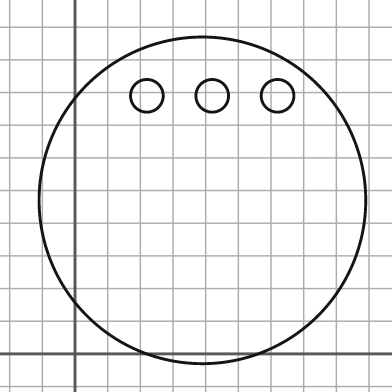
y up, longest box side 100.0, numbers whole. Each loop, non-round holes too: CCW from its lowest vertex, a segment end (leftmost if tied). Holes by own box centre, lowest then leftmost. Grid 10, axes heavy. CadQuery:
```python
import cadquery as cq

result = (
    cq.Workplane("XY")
    .moveTo(39.0, 47.0)
    .circle(50.0)
    .moveTo(22.0, 79.0)
    .circle(5.0)
    .moveTo(42.0, 79.0)
    .circle(5.0)
    .moveTo(62.0, 79.0)
    .circle(5.0)
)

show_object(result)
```